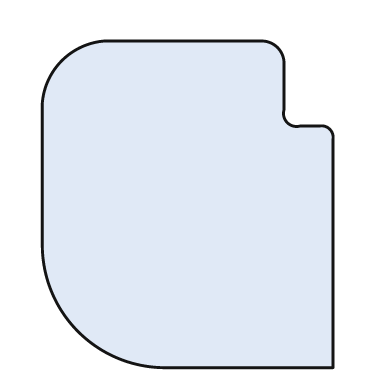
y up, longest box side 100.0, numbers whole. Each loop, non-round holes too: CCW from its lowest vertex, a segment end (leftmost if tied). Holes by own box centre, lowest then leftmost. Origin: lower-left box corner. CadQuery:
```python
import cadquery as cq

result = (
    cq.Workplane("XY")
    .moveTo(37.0, 0.0)
    .lineTo(89.0, 0.0)
    .lineTo(89.0, 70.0)
    .threePointArc((88.0, 73.0), (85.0, 74.0))
    .lineTo(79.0, 74.0)
    .threePointArc((75.0, 75.0), (74.0, 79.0))
    .lineTo(74.0, 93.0)
    .threePointArc((72.0, 98.0), (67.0, 100.0))
    .lineTo(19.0, 100.0)
    .threePointArc((6.0, 94.0), (0.0, 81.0))
    .lineTo(0.0, 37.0)
    .threePointArc((11.0, 11.0), (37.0, 0.0))
    .close()
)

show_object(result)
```